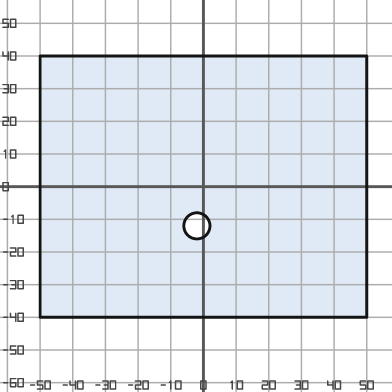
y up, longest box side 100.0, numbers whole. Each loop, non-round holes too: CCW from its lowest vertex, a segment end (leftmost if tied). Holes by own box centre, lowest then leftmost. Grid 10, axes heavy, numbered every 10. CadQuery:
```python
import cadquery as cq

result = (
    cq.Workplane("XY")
    .moveTo(-50.0, -40.0)
    .lineTo(50.0, -40.0)
    .lineTo(50.0, 40.0)
    .lineTo(-50.0, 40.0)
    .close()
    .moveTo(-2.0, -12.0)
    .circle(4.0)
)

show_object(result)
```